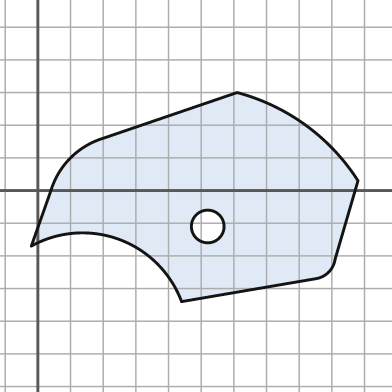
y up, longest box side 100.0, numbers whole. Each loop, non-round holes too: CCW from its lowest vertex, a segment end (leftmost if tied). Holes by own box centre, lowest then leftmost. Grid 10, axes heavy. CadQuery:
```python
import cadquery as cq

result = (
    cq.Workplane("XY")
    .moveTo(44.0, -34.0)
    .lineTo(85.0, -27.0)
    .threePointArc((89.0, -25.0), (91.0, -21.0))
    .lineTo(98.0, 3.0)
    .threePointArc((82.0, 20.0), (61.0, 30.0))
    .lineTo(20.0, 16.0)
    .threePointArc((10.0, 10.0), (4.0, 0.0))
    .lineTo(-2.0, -17.0)
    .threePointArc((25.0, -15.0), (44.0, -34.0))
    .close()
    .moveTo(52.0, -11.0)
    .circle(5.0)
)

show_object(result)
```